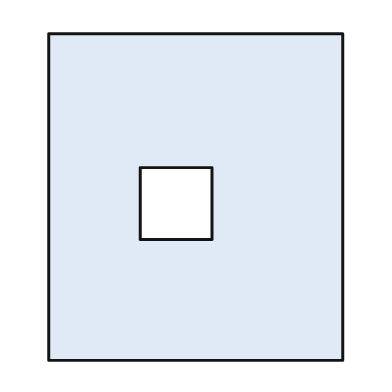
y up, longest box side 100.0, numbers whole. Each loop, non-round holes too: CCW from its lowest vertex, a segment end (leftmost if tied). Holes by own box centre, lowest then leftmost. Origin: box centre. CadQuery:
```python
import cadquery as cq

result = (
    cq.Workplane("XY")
    .moveTo(-45.0, -50.0)
    .lineTo(45.0, -50.0)
    .lineTo(45.0, 50.0)
    .lineTo(-45.0, 50.0)
    .close()
    .moveTo(-17.0, -13.0)
    .lineTo(5.0, -13.0)
    .lineTo(5.0, 9.0)
    .lineTo(-17.0, 9.0)
    .close()
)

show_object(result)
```